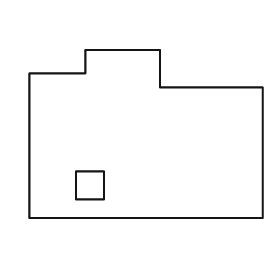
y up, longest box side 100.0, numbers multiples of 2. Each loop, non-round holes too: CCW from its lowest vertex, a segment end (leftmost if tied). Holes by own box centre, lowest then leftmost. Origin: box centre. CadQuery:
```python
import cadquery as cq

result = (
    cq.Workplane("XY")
    .moveTo(-50.0, -36.0)
    .lineTo(50.0, -36.0)
    .lineTo(50.0, 20.0)
    .lineTo(6.0, 20.0)
    .lineTo(6.0, 36.0)
    .lineTo(-26.0, 36.0)
    .lineTo(-26.0, 26.0)
    .lineTo(-50.0, 26.0)
    .close()
    .moveTo(-30.0, -28.0)
    .lineTo(-18.0, -28.0)
    .lineTo(-18.0, -16.0)
    .lineTo(-30.0, -16.0)
    .close()
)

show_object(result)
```